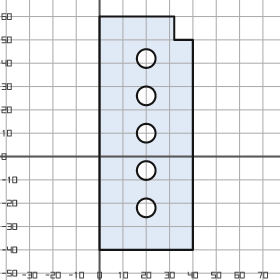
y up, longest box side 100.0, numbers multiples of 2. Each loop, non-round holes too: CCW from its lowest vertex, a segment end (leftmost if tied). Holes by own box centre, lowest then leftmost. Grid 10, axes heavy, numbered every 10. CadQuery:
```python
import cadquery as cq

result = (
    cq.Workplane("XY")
    .moveTo(0.0, -40.0)
    .lineTo(40.0, -40.0)
    .lineTo(40.0, 50.0)
    .lineTo(32.0, 50.0)
    .lineTo(32.0, 60.0)
    .lineTo(0.0, 60.0)
    .close()
    .moveTo(20.0, -22.0)
    .circle(4.0)
    .moveTo(20.0, -6.0)
    .circle(4.0)
    .moveTo(20.0, 10.0)
    .circle(4.0)
    .moveTo(20.0, 26.0)
    .circle(4.0)
    .moveTo(20.0, 42.0)
    .circle(4.0)
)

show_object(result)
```